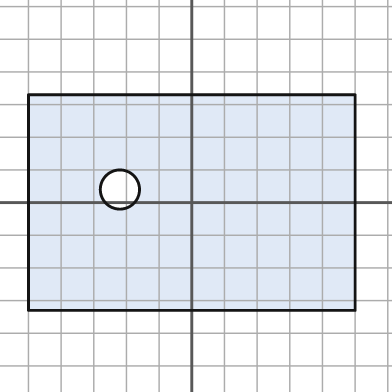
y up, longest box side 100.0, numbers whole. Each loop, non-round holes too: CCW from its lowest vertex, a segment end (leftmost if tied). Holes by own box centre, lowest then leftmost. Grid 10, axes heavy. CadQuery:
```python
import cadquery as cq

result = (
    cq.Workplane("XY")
    .moveTo(-50.0, -33.0)
    .lineTo(50.0, -33.0)
    .lineTo(50.0, 33.0)
    .lineTo(-50.0, 33.0)
    .close()
    .moveTo(-22.0, 4.0)
    .circle(6.0)
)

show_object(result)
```